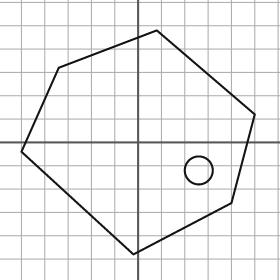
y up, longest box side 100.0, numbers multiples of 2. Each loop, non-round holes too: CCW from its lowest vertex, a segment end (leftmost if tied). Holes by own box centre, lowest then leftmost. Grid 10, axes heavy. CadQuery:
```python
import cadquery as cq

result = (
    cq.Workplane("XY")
    .moveTo(-2.0, -48.0)
    .lineTo(40.0, -26.0)
    .lineTo(50.0, 12.0)
    .lineTo(8.0, 48.0)
    .lineTo(-34.0, 32.0)
    .lineTo(-50.0, -4.0)
    .close()
    .moveTo(26.0, -12.0)
    .circle(6.0)
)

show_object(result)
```